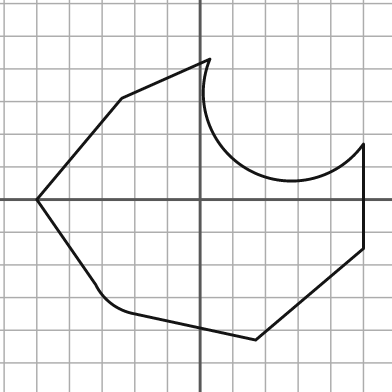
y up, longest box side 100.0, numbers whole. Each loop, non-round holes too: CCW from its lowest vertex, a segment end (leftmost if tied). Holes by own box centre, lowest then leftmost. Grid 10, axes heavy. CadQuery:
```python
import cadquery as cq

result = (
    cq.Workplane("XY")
    .moveTo(17.0, -43.0)
    .lineTo(50.0, -15.0)
    .lineTo(50.0, 17.0)
    .threePointArc((15.0, 9.0), (3.0, 43.0))
    .lineTo(-24.0, 31.0)
    .lineTo(-50.0, 0.0)
    .lineTo(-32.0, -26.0)
    .threePointArc((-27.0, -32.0), (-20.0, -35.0))
    .close()
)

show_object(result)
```